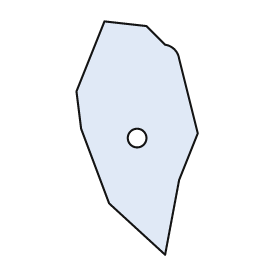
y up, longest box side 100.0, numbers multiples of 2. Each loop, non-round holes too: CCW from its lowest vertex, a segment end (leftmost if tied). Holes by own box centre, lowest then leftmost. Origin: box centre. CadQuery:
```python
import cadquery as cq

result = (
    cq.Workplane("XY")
    .moveTo(12.0, -50.0)
    .lineTo(18.0, -18.0)
    .lineTo(26.0, 2.0)
    .lineTo(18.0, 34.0)
    .threePointArc((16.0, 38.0), (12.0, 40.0))
    .lineTo(4.0, 48.0)
    .lineTo(-14.0, 50.0)
    .lineTo(-26.0, 20.0)
    .lineTo(-24.0, 4.0)
    .lineTo(-12.0, -28.0)
    .close()
    .moveTo(0.0, 0.0)
    .circle(4.0)
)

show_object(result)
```